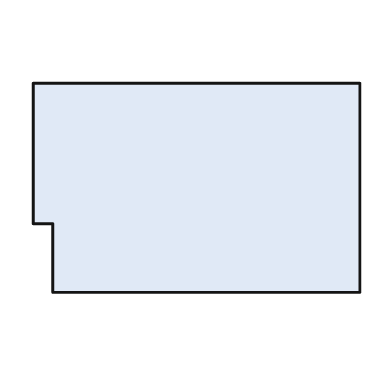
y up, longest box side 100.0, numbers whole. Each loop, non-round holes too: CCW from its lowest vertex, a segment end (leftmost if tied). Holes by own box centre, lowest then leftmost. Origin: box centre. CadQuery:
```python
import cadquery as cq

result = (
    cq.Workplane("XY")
    .moveTo(-44.0, -32.0)
    .lineTo(50.0, -32.0)
    .lineTo(50.0, 32.0)
    .lineTo(-50.0, 32.0)
    .lineTo(-50.0, -11.0)
    .lineTo(-44.0, -11.0)
    .close()
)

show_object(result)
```